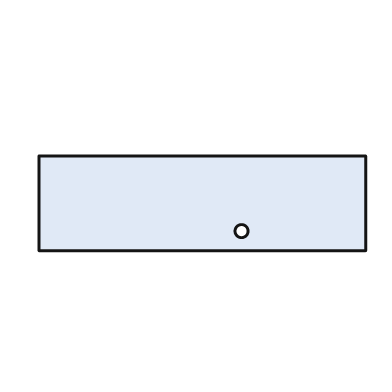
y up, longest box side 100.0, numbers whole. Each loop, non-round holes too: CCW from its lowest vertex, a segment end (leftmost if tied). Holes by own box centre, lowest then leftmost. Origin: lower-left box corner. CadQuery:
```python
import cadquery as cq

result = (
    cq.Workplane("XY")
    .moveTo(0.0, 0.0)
    .lineTo(100.0, 0.0)
    .lineTo(100.0, 29.0)
    .lineTo(0.0, 29.0)
    .close()
    .moveTo(62.0, 6.0)
    .circle(2.0)
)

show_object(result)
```